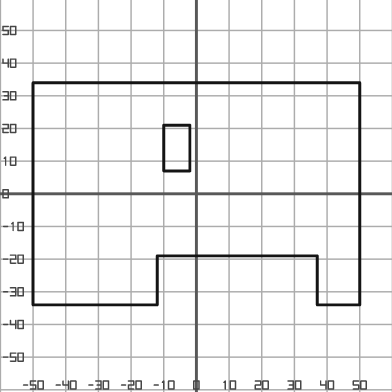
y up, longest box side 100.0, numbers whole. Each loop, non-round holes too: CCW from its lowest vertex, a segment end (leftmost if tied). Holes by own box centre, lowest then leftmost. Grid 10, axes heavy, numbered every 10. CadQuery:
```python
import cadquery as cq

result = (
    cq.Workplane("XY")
    .moveTo(-50.0, -34.0)
    .lineTo(-12.0, -34.0)
    .lineTo(-12.0, -19.0)
    .lineTo(37.0, -19.0)
    .lineTo(37.0, -34.0)
    .lineTo(50.0, -34.0)
    .lineTo(50.0, 34.0)
    .lineTo(-50.0, 34.0)
    .close()
    .moveTo(-10.0, 7.0)
    .lineTo(-2.0, 7.0)
    .lineTo(-2.0, 21.0)
    .lineTo(-10.0, 21.0)
    .close()
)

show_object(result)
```